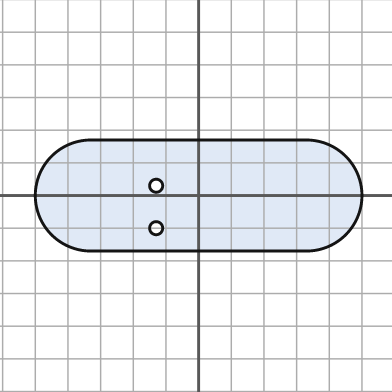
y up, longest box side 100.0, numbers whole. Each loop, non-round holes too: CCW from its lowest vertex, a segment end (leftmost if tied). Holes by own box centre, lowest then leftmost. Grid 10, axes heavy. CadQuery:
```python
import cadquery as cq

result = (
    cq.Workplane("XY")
    .moveTo(-33.0, -17.0)
    .lineTo(33.0, -17.0)
    .threePointArc((50.0, 0.0), (33.0, 17.0))
    .lineTo(-33.0, 17.0)
    .threePointArc((-50.0, 0.0), (-33.0, -17.0))
    .close()
    .moveTo(-13.0, -10.0)
    .circle(2.0)
    .moveTo(-13.0, 3.0)
    .circle(2.0)
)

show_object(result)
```